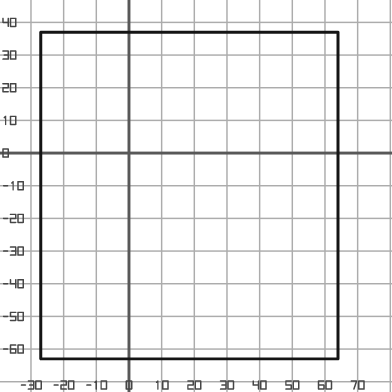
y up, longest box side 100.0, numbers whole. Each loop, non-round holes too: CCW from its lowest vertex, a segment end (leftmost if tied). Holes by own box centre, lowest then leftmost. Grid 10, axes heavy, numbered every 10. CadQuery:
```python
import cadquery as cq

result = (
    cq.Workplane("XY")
    .moveTo(-27.0, -63.0)
    .lineTo(64.0, -63.0)
    .lineTo(64.0, 37.0)
    .lineTo(-27.0, 37.0)
    .close()
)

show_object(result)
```